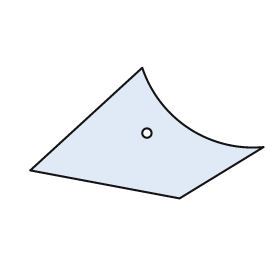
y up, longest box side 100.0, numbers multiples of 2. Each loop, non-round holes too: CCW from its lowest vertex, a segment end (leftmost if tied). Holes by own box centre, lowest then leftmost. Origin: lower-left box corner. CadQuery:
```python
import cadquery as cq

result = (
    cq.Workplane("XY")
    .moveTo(64.0, 0.0)
    .lineTo(100.0, 22.0)
    .threePointArc((68.0, 30.0), (48.0, 56.0))
    .lineTo(0.0, 12.0)
    .close()
    .moveTo(50.0, 28.0)
    .circle(2.0)
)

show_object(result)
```